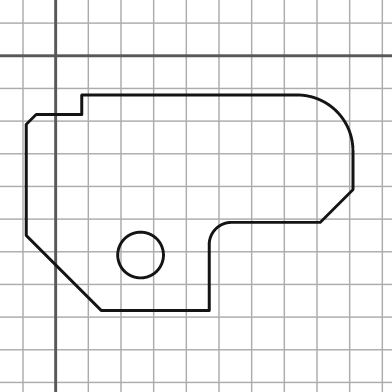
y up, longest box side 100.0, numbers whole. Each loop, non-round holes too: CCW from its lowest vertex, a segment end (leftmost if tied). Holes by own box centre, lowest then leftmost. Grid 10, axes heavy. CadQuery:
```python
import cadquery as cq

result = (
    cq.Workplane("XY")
    .moveTo(14.0, -78.0)
    .lineTo(47.0, -78.0)
    .lineTo(47.0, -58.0)
    .threePointArc((49.0, -53.0), (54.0, -51.0))
    .lineTo(81.0, -51.0)
    .lineTo(91.0, -41.0)
    .lineTo(91.0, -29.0)
    .threePointArc((86.0, -17.0), (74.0, -12.0))
    .lineTo(8.0, -12.0)
    .lineTo(8.0, -18.0)
    .lineTo(-6.0, -18.0)
    .lineTo(-9.0, -21.0)
    .lineTo(-9.0, -55.0)
    .close()
    .moveTo(26.0, -61.0)
    .circle(7.0)
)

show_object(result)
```